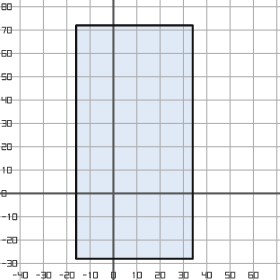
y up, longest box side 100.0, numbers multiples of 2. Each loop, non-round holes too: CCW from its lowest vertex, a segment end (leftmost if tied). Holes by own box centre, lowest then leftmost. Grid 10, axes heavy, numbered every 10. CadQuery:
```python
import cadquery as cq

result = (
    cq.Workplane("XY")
    .moveTo(-16.0, -28.0)
    .lineTo(34.0, -28.0)
    .lineTo(34.0, 72.0)
    .lineTo(-16.0, 72.0)
    .close()
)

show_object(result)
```